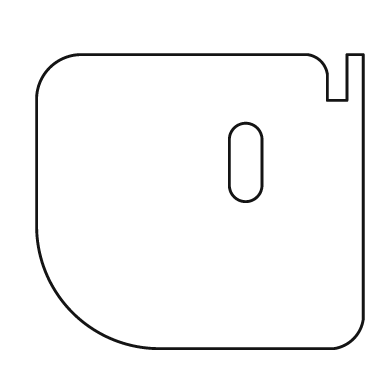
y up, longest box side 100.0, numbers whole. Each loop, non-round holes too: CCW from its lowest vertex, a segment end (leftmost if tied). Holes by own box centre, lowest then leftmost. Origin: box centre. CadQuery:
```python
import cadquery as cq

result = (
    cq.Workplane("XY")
    .moveTo(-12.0, -45.0)
    .lineTo(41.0, -45.0)
    .threePointArc((47.0, -42.0), (50.0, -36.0))
    .lineTo(50.0, 45.0)
    .lineTo(45.0, 45.0)
    .lineTo(45.0, 31.0)
    .lineTo(39.0, 31.0)
    .lineTo(39.0, 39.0)
    .threePointArc((37.0, 43.0), (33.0, 45.0))
    .lineTo(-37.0, 45.0)
    .threePointArc((-46.0, 41.0), (-50.0, 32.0))
    .lineTo(-50.0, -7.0)
    .threePointArc((-39.0, -34.0), (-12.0, -45.0))
    .close()
    .moveTo(9.0, 5.0)
    .threePointArc((14.0, 0.0), (19.0, 5.0))
    .lineTo(19.0, 19.0)
    .threePointArc((14.0, 24.0), (9.0, 19.0))
    .close()
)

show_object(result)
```